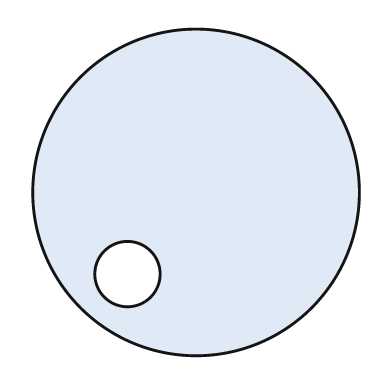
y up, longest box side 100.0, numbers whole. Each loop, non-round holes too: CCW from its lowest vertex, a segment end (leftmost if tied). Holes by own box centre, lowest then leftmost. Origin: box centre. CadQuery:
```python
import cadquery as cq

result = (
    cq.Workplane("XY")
    .moveTo(0.0, 0.0)
    .circle(50.0)
    .moveTo(-21.0, -25.0)
    .circle(10.0)
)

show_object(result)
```